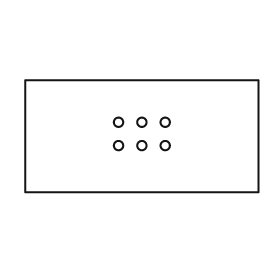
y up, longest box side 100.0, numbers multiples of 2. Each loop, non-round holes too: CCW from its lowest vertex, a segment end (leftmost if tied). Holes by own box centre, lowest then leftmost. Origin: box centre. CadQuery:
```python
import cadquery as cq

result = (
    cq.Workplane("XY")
    .moveTo(-50.0, -24.0)
    .lineTo(50.0, -24.0)
    .lineTo(50.0, 24.0)
    .lineTo(-50.0, 24.0)
    .close()
    .moveTo(-10.0, -4.0)
    .circle(2.0)
    .moveTo(0.0, -4.0)
    .circle(2.0)
    .moveTo(10.0, -4.0)
    .circle(2.0)
    .moveTo(-10.0, 6.0)
    .circle(2.0)
    .moveTo(0.0, 6.0)
    .circle(2.0)
    .moveTo(10.0, 6.0)
    .circle(2.0)
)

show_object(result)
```